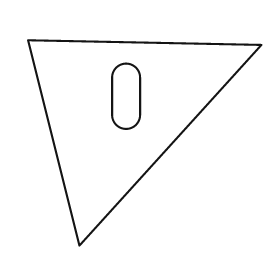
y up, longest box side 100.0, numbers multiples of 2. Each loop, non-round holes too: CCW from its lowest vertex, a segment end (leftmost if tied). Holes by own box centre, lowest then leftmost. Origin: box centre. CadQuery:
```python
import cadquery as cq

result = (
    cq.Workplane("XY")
    .moveTo(-28.0, -44.0)
    .lineTo(50.0, 42.0)
    .lineTo(-50.0, 44.0)
    .close()
    .moveTo(-14.0, 12.0)
    .threePointArc((-8.0, 6.0), (-2.0, 12.0))
    .lineTo(-2.0, 28.0)
    .threePointArc((-8.0, 34.0), (-14.0, 28.0))
    .close()
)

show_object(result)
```